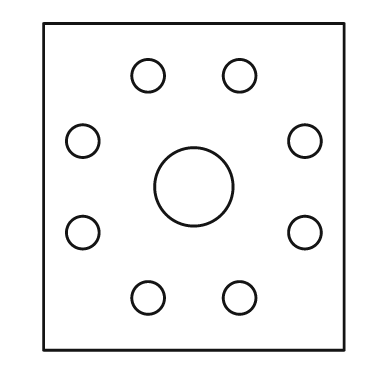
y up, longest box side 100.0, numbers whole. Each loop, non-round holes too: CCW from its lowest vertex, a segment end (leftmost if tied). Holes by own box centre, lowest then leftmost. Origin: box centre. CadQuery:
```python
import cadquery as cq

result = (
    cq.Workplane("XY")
    .moveTo(-46.0, -50.0)
    .lineTo(46.0, -50.0)
    .lineTo(46.0, 50.0)
    .lineTo(-46.0, 50.0)
    .close()
    .moveTo(-14.0, -34.0)
    .circle(5.0)
    .moveTo(14.0, -34.0)
    .circle(5.0)
    .moveTo(-34.0, -14.0)
    .circle(5.0)
    .moveTo(34.0, -14.0)
    .circle(5.0)
    .moveTo(0.0, 0.0)
    .circle(12.0)
    .moveTo(-34.0, 14.0)
    .circle(5.0)
    .moveTo(34.0, 14.0)
    .circle(5.0)
    .moveTo(-14.0, 34.0)
    .circle(5.0)
    .moveTo(14.0, 34.0)
    .circle(5.0)
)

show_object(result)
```